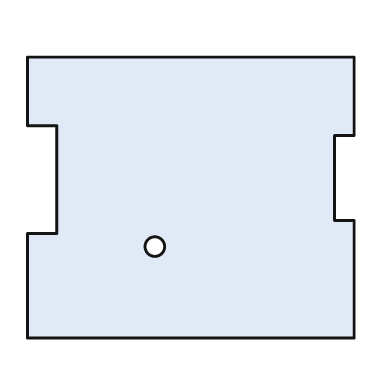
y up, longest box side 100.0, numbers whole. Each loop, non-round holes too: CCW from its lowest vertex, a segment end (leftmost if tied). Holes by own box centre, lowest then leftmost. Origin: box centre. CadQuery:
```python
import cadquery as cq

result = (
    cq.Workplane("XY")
    .moveTo(-50.0, -43.0)
    .lineTo(50.0, -43.0)
    .lineTo(50.0, -7.0)
    .lineTo(44.0, -7.0)
    .lineTo(44.0, 19.0)
    .lineTo(50.0, 19.0)
    .lineTo(50.0, 43.0)
    .lineTo(-50.0, 43.0)
    .lineTo(-50.0, 22.0)
    .lineTo(-41.0, 22.0)
    .lineTo(-41.0, -11.0)
    .lineTo(-50.0, -11.0)
    .close()
    .moveTo(-11.0, -15.0)
    .circle(3.0)
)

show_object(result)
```